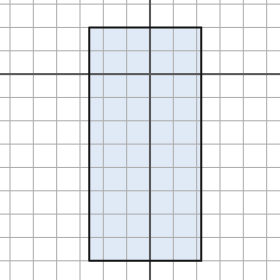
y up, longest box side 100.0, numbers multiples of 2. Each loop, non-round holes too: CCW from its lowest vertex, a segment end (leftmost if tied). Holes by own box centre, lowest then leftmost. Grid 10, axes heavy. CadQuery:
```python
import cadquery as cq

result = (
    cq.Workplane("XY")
    .moveTo(-26.0, -80.0)
    .lineTo(22.0, -80.0)
    .lineTo(22.0, 20.0)
    .lineTo(-26.0, 20.0)
    .close()
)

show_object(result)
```